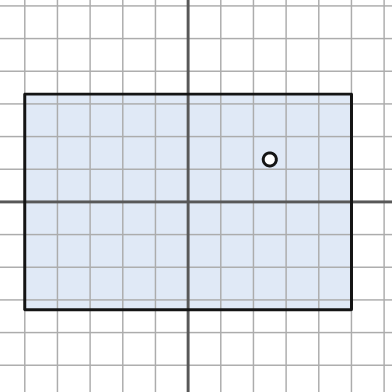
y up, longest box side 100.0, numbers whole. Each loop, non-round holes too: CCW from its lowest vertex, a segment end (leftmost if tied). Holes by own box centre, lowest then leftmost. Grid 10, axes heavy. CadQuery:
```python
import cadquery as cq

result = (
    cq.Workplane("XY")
    .moveTo(-50.0, -33.0)
    .lineTo(50.0, -33.0)
    .lineTo(50.0, 33.0)
    .lineTo(-50.0, 33.0)
    .close()
    .moveTo(25.0, 13.0)
    .circle(2.0)
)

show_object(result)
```